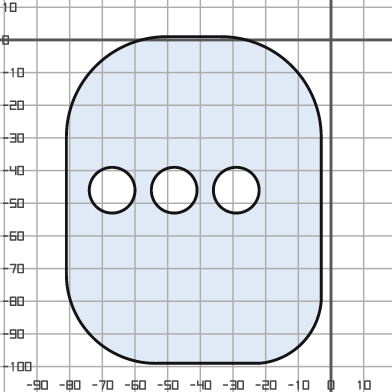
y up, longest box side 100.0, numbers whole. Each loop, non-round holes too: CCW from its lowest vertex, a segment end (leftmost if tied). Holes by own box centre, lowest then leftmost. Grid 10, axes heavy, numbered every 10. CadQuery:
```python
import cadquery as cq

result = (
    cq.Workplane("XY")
    .moveTo(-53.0, -99.0)
    .lineTo(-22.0, -99.0)
    .threePointArc((-9.0, -93.0), (-3.0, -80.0))
    .lineTo(-3.0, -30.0)
    .threePointArc((-12.0, -8.0), (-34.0, 1.0))
    .lineTo(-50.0, 1.0)
    .threePointArc((-72.0, -8.0), (-81.0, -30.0))
    .lineTo(-81.0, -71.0)
    .threePointArc((-73.0, -91.0), (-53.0, -99.0))
    .close()
    .moveTo(-67.0, -46.0)
    .circle(7.0)
    .moveTo(-48.0, -46.0)
    .circle(7.0)
    .moveTo(-29.0, -46.0)
    .circle(7.0)
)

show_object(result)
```